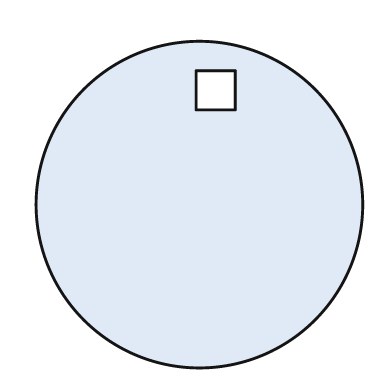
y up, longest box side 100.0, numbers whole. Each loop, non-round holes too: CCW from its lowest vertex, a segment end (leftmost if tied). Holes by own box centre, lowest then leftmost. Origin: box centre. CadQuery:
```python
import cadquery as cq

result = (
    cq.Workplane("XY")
    .moveTo(0.0, 0.0)
    .circle(50.0)
    .moveTo(-1.0, 29.0)
    .lineTo(11.0, 29.0)
    .lineTo(11.0, 41.0)
    .lineTo(-1.0, 41.0)
    .close()
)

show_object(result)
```